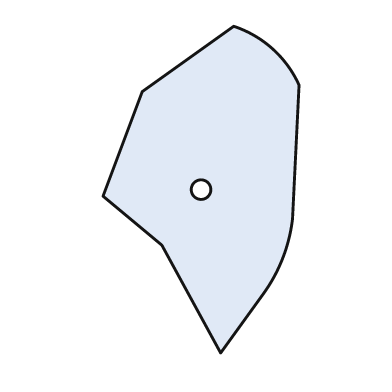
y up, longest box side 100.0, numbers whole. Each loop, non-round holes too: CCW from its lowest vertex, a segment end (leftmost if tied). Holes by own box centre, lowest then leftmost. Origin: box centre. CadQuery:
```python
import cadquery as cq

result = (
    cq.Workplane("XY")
    .moveTo(6.0, -50.0)
    .lineTo(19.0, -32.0)
    .threePointArc((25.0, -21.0), (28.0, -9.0))
    .lineTo(30.0, 32.0)
    .threePointArc((22.0, 43.0), (10.0, 50.0))
    .lineTo(-18.0, 30.0)
    .lineTo(-30.0, -2.0)
    .lineTo(-12.0, -17.0)
    .close()
    .moveTo(0.0, 0.0)
    .circle(3.0)
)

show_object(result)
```